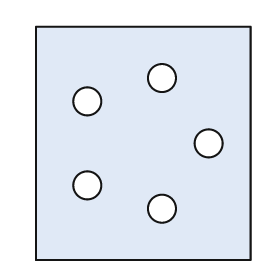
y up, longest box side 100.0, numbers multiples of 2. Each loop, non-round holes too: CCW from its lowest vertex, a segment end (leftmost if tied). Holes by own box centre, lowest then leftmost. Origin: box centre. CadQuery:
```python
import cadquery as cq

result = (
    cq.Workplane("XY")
    .moveTo(-46.0, -50.0)
    .lineTo(46.0, -50.0)
    .lineTo(46.0, 50.0)
    .lineTo(-46.0, 50.0)
    .close()
    .moveTo(8.0, -28.0)
    .circle(6.0)
    .moveTo(-24.0, -18.0)
    .circle(6.0)
    .moveTo(28.0, 0.0)
    .circle(6.0)
    .moveTo(-24.0, 18.0)
    .circle(6.0)
    .moveTo(8.0, 28.0)
    .circle(6.0)
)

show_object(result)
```